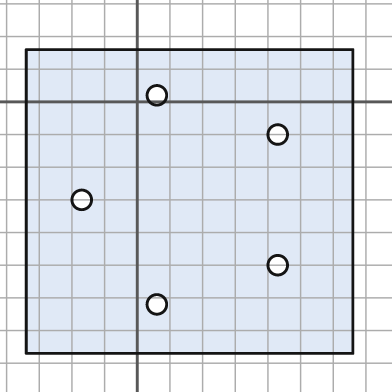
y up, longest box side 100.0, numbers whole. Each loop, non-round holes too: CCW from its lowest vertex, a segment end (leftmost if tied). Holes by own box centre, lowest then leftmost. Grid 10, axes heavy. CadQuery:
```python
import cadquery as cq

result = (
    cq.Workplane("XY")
    .moveTo(-34.0, -77.0)
    .lineTo(66.0, -77.0)
    .lineTo(66.0, 16.0)
    .lineTo(-34.0, 16.0)
    .close()
    .moveTo(6.0, -62.0)
    .circle(3.0)
    .moveTo(43.0, -50.0)
    .circle(3.0)
    .moveTo(-17.0, -30.0)
    .circle(3.0)
    .moveTo(43.0, -10.0)
    .circle(3.0)
    .moveTo(6.0, 2.0)
    .circle(3.0)
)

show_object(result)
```